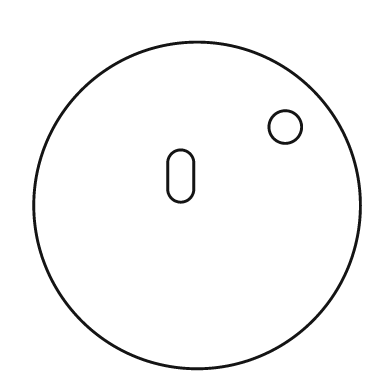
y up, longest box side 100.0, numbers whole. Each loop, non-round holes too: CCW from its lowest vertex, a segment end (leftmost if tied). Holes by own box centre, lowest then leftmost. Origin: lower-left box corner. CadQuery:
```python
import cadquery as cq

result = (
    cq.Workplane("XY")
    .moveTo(50.0, 50.0)
    .circle(50.0)
    .moveTo(41.0, 55.0)
    .threePointArc((45.0, 51.0), (49.0, 55.0))
    .lineTo(49.0, 63.0)
    .threePointArc((45.0, 67.0), (41.0, 63.0))
    .close()
    .moveTo(77.0, 74.0)
    .circle(5.0)
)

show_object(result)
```